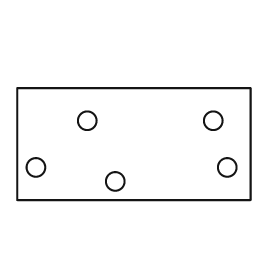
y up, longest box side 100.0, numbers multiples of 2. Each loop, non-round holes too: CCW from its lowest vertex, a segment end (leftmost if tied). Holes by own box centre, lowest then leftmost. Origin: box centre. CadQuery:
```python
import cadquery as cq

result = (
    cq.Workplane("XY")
    .moveTo(-50.0, -24.0)
    .lineTo(50.0, -24.0)
    .lineTo(50.0, 24.0)
    .lineTo(-50.0, 24.0)
    .close()
    .moveTo(-8.0, -16.0)
    .circle(4.0)
    .moveTo(-42.0, -10.0)
    .circle(4.0)
    .moveTo(40.0, -10.0)
    .circle(4.0)
    .moveTo(-20.0, 10.0)
    .circle(4.0)
    .moveTo(34.0, 10.0)
    .circle(4.0)
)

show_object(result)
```